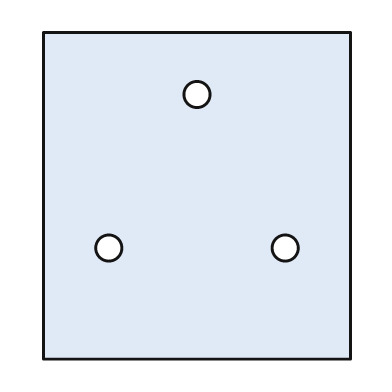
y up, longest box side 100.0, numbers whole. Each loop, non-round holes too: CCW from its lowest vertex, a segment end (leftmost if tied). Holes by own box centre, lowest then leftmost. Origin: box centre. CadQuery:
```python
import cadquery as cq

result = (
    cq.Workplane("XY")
    .moveTo(-47.0, -50.0)
    .lineTo(47.0, -50.0)
    .lineTo(47.0, 50.0)
    .lineTo(-47.0, 50.0)
    .close()
    .moveTo(-27.0, -16.0)
    .circle(4.0)
    .moveTo(27.0, -16.0)
    .circle(4.0)
    .moveTo(0.0, 31.0)
    .circle(4.0)
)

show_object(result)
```